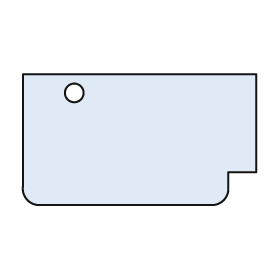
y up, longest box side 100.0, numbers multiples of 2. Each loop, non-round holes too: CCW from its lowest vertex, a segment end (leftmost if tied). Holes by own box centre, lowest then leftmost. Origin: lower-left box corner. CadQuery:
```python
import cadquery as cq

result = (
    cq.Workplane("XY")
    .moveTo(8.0, 0.0)
    .lineTo(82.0, 0.0)
    .threePointArc((86.0, 2.0), (88.0, 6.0))
    .lineTo(88.0, 14.0)
    .lineTo(100.0, 14.0)
    .lineTo(100.0, 56.0)
    .lineTo(0.0, 56.0)
    .lineTo(0.0, 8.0)
    .threePointArc((2.0, 2.0), (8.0, 0.0))
    .close()
    .moveTo(22.0, 48.0)
    .circle(4.0)
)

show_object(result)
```